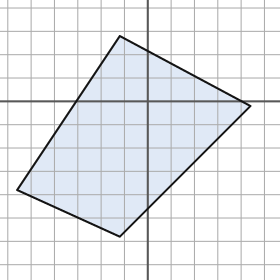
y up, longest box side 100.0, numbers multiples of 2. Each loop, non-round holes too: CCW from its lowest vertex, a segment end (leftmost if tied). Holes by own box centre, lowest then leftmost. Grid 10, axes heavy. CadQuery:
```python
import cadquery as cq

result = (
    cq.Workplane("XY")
    .moveTo(-12.0, -58.0)
    .lineTo(44.0, -2.0)
    .lineTo(-12.0, 28.0)
    .lineTo(-56.0, -38.0)
    .close()
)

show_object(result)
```